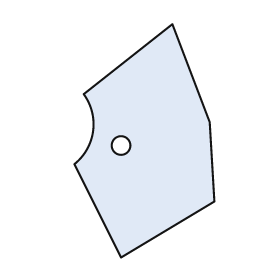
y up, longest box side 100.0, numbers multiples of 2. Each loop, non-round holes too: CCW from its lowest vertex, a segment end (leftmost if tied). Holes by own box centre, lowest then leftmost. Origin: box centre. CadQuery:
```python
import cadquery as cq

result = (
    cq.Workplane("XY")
    .moveTo(-10.0, -50.0)
    .lineTo(30.0, -26.0)
    .lineTo(28.0, 8.0)
    .lineTo(12.0, 50.0)
    .lineTo(-26.0, 20.0)
    .threePointArc((-22.0, 4.0), (-30.0, -10.0))
    .close()
    .moveTo(-10.0, -2.0)
    .circle(4.0)
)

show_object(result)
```